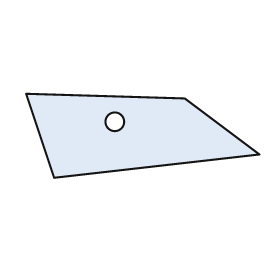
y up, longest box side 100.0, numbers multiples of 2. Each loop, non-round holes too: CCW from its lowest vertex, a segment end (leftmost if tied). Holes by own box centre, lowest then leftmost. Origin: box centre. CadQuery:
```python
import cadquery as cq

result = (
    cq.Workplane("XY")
    .moveTo(-38.0, -18.0)
    .lineTo(50.0, -8.0)
    .lineTo(18.0, 16.0)
    .lineTo(-50.0, 18.0)
    .close()
    .moveTo(-12.0, 6.0)
    .circle(4.0)
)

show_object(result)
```